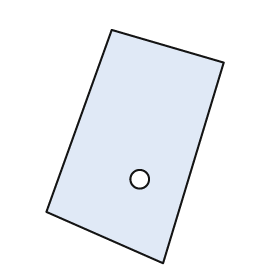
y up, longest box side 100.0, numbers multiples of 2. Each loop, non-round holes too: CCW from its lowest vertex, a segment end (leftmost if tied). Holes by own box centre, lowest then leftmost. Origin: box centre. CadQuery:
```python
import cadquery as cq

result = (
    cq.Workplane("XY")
    .moveTo(12.0, -50.0)
    .lineTo(38.0, 36.0)
    .lineTo(-10.0, 50.0)
    .lineTo(-38.0, -28.0)
    .close()
    .moveTo(2.0, -14.0)
    .circle(4.0)
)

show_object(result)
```